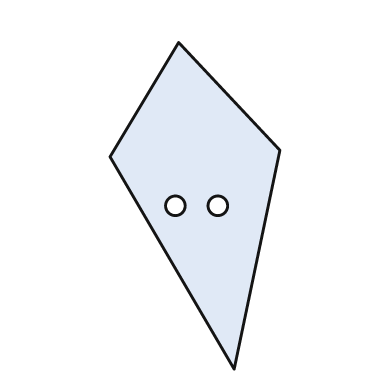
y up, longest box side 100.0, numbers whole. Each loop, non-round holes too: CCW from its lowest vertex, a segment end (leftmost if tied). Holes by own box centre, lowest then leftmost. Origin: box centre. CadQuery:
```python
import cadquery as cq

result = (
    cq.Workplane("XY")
    .moveTo(12.0, -50.0)
    .lineTo(26.0, 17.0)
    .lineTo(-5.0, 50.0)
    .lineTo(-26.0, 15.0)
    .close()
    .moveTo(-6.0, 0.0)
    .circle(3.0)
    .moveTo(7.0, 0.0)
    .circle(3.0)
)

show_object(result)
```